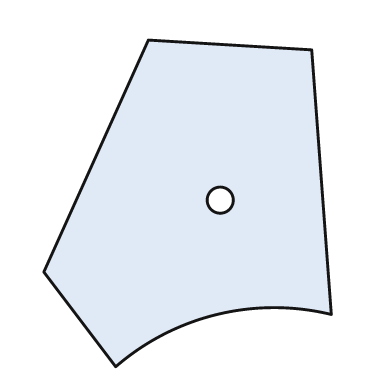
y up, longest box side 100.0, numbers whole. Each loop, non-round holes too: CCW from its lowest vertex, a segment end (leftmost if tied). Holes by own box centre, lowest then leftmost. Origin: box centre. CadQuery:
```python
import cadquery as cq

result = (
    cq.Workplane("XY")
    .moveTo(-22.0, -50.0)
    .threePointArc((9.0, -34.0), (44.0, -34.0))
    .lineTo(38.0, 47.0)
    .lineTo(-12.0, 50.0)
    .lineTo(-44.0, -21.0)
    .close()
    .moveTo(10.0, 1.0)
    .circle(4.0)
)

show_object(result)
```